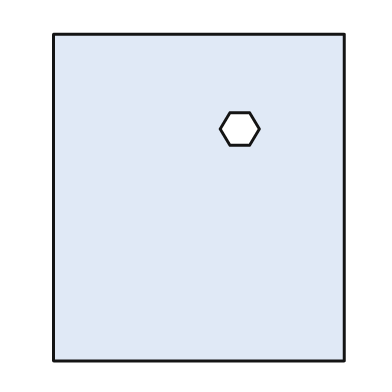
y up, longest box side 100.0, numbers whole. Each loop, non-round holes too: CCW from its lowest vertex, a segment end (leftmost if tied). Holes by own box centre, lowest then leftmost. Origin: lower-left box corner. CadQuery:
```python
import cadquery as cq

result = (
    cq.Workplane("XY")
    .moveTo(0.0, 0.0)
    .lineTo(89.0, 0.0)
    .lineTo(89.0, 100.0)
    .lineTo(0.0, 100.0)
    .close()
    .moveTo(54.0, 66.0)
    .lineTo(60.0, 66.0)
    .lineTo(63.0, 71.0)
    .lineTo(60.0, 76.0)
    .lineTo(54.0, 76.0)
    .lineTo(51.0, 71.0)
    .close()
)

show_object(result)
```